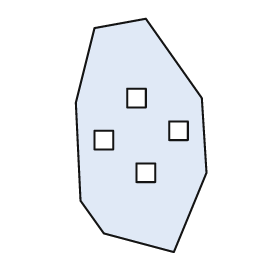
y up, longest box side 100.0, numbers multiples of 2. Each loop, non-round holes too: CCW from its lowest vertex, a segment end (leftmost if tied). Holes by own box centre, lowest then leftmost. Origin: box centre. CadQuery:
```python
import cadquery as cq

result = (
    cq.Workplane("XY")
    .moveTo(14.0, -50.0)
    .lineTo(28.0, -16.0)
    .lineTo(26.0, 16.0)
    .lineTo(2.0, 50.0)
    .lineTo(-20.0, 46.0)
    .lineTo(-28.0, 14.0)
    .lineTo(-26.0, -28.0)
    .lineTo(-16.0, -42.0)
    .close()
    .moveTo(-2.0, -20.0)
    .lineTo(6.0, -20.0)
    .lineTo(6.0, -12.0)
    .lineTo(-2.0, -12.0)
    .close()
    .moveTo(-20.0, -6.0)
    .lineTo(-12.0, -6.0)
    .lineTo(-12.0, 2.0)
    .lineTo(-20.0, 2.0)
    .close()
    .moveTo(12.0, -2.0)
    .lineTo(20.0, -2.0)
    .lineTo(20.0, 6.0)
    .lineTo(12.0, 6.0)
    .close()
    .moveTo(-6.0, 12.0)
    .lineTo(2.0, 12.0)
    .lineTo(2.0, 20.0)
    .lineTo(-6.0, 20.0)
    .close()
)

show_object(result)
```